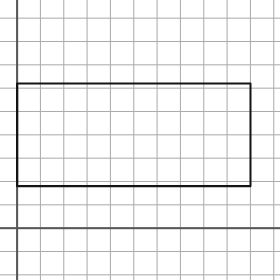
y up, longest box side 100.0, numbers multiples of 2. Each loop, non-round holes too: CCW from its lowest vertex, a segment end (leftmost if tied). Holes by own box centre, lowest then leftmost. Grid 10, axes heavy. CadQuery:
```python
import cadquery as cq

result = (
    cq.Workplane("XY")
    .moveTo(0.0, 18.0)
    .lineTo(100.0, 18.0)
    .lineTo(100.0, 62.0)
    .lineTo(0.0, 62.0)
    .close()
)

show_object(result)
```